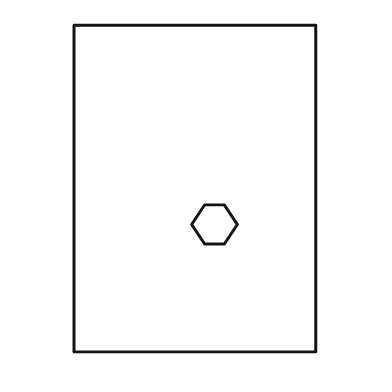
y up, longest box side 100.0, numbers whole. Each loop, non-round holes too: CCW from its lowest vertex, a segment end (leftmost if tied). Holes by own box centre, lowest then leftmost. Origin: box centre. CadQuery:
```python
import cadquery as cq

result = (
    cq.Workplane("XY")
    .moveTo(-37.0, -50.0)
    .lineTo(37.0, -50.0)
    .lineTo(37.0, 50.0)
    .lineTo(-37.0, 50.0)
    .close()
    .moveTo(3.0, -17.0)
    .lineTo(9.0, -17.0)
    .lineTo(13.0, -11.0)
    .lineTo(9.0, -5.0)
    .lineTo(3.0, -5.0)
    .lineTo(-1.0, -11.0)
    .close()
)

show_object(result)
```